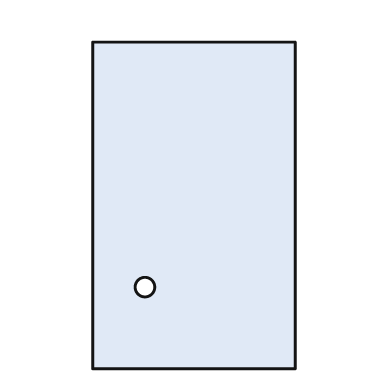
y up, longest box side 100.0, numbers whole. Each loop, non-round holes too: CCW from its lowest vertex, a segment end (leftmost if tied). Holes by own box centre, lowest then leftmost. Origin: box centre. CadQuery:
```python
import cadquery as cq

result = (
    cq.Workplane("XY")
    .moveTo(-31.0, -50.0)
    .lineTo(31.0, -50.0)
    .lineTo(31.0, 50.0)
    .lineTo(-31.0, 50.0)
    .close()
    .moveTo(-15.0, -25.0)
    .circle(3.0)
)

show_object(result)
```